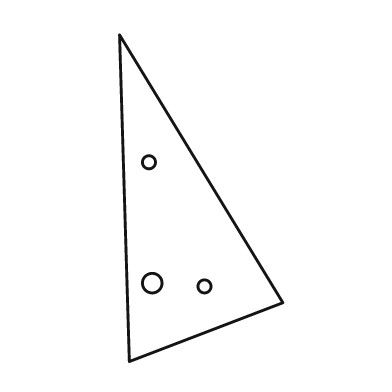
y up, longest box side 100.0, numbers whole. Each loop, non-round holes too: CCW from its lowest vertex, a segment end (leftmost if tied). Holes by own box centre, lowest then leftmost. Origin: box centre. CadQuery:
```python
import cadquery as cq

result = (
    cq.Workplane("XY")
    .moveTo(-22.0, -50.0)
    .lineTo(25.0, -32.0)
    .lineTo(-25.0, 50.0)
    .close()
    .moveTo(1.0, -27.0)
    .circle(2.0)
    .moveTo(-15.0, -26.0)
    .circle(3.0)
    .moveTo(-16.0, 11.0)
    .circle(2.0)
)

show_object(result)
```